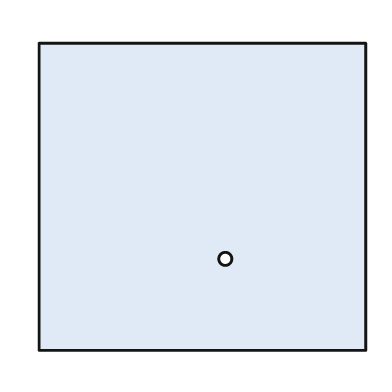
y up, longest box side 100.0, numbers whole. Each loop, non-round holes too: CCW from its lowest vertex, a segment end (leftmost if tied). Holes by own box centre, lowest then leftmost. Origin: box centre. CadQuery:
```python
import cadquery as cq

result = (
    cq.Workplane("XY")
    .moveTo(-50.0, -47.0)
    .lineTo(50.0, -47.0)
    .lineTo(50.0, 47.0)
    .lineTo(-50.0, 47.0)
    .close()
    .moveTo(7.0, -19.0)
    .circle(2.0)
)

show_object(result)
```